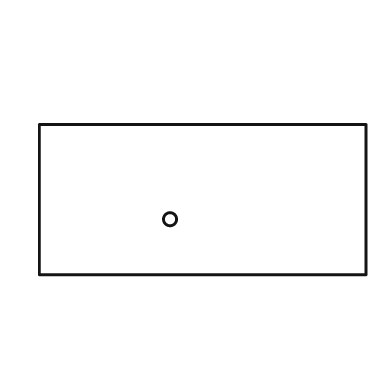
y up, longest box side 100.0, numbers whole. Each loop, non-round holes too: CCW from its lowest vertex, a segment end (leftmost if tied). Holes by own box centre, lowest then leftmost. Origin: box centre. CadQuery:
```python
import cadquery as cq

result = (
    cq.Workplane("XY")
    .moveTo(-50.0, -23.0)
    .lineTo(50.0, -23.0)
    .lineTo(50.0, 23.0)
    .lineTo(-50.0, 23.0)
    .close()
    .moveTo(-10.0, -6.0)
    .circle(2.0)
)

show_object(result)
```